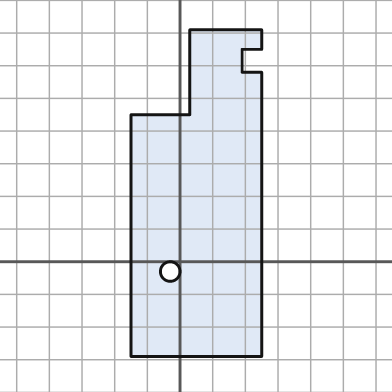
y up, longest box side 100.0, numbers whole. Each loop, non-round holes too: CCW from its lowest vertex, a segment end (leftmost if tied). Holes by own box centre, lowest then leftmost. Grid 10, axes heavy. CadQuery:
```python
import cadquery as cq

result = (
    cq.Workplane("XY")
    .moveTo(-15.0, -29.0)
    .lineTo(25.0, -29.0)
    .lineTo(25.0, 58.0)
    .lineTo(19.0, 58.0)
    .lineTo(19.0, 65.0)
    .lineTo(25.0, 65.0)
    .lineTo(25.0, 71.0)
    .lineTo(3.0, 71.0)
    .lineTo(3.0, 45.0)
    .lineTo(-15.0, 45.0)
    .close()
    .moveTo(-3.0, -3.0)
    .circle(3.0)
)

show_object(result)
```